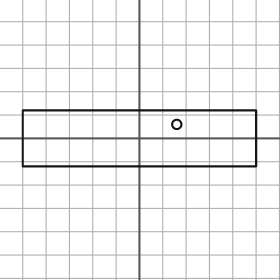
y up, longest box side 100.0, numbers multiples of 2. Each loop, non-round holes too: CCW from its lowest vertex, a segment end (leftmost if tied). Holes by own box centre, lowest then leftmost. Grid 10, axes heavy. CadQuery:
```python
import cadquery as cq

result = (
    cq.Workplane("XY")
    .moveTo(-50.0, -12.0)
    .lineTo(50.0, -12.0)
    .lineTo(50.0, 12.0)
    .lineTo(-50.0, 12.0)
    .close()
    .moveTo(16.0, 6.0)
    .circle(2.0)
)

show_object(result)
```